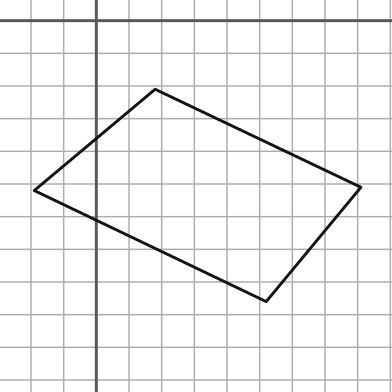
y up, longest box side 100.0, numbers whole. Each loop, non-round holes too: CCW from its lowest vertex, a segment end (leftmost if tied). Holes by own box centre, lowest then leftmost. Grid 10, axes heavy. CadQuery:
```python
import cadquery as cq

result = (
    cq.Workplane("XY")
    .moveTo(52.0, -86.0)
    .lineTo(81.0, -51.0)
    .lineTo(18.0, -21.0)
    .lineTo(-19.0, -52.0)
    .close()
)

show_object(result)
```